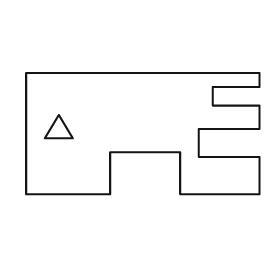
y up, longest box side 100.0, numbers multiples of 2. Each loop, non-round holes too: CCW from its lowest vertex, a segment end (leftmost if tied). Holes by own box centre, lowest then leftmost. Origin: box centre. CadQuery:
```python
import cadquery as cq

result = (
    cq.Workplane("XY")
    .moveTo(-50.0, -26.0)
    .lineTo(-14.0, -26.0)
    .lineTo(-14.0, -8.0)
    .lineTo(16.0, -8.0)
    .lineTo(16.0, -26.0)
    .lineTo(50.0, -26.0)
    .lineTo(50.0, -10.0)
    .lineTo(24.0, -10.0)
    .lineTo(24.0, 2.0)
    .lineTo(50.0, 2.0)
    .lineTo(50.0, 12.0)
    .lineTo(30.0, 12.0)
    .lineTo(30.0, 20.0)
    .lineTo(50.0, 20.0)
    .lineTo(50.0, 26.0)
    .lineTo(-50.0, 26.0)
    .close()
    .moveTo(-42.0, -2.0)
    .lineTo(-30.0, -2.0)
    .lineTo(-36.0, 8.0)
    .close()
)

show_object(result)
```